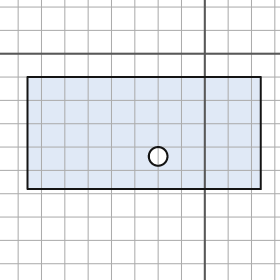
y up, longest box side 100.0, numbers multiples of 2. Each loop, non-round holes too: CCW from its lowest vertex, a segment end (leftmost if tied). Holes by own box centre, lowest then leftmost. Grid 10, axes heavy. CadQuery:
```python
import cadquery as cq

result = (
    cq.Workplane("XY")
    .moveTo(-76.0, -58.0)
    .lineTo(24.0, -58.0)
    .lineTo(24.0, -10.0)
    .lineTo(-76.0, -10.0)
    .close()
    .moveTo(-20.0, -44.0)
    .circle(4.0)
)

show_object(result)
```